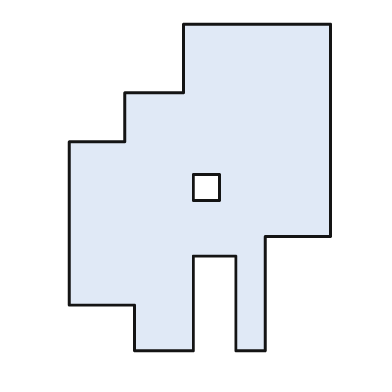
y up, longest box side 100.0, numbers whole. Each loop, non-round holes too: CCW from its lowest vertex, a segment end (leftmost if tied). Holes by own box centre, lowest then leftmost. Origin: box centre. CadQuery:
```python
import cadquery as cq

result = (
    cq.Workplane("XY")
    .moveTo(-20.0, -50.0)
    .lineTo(-2.0, -50.0)
    .lineTo(-2.0, -21.0)
    .lineTo(11.0, -21.0)
    .lineTo(11.0, -50.0)
    .lineTo(20.0, -50.0)
    .lineTo(20.0, -15.0)
    .lineTo(40.0, -15.0)
    .lineTo(40.0, 50.0)
    .lineTo(-5.0, 50.0)
    .lineTo(-5.0, 29.0)
    .lineTo(-23.0, 29.0)
    .lineTo(-23.0, 14.0)
    .lineTo(-40.0, 14.0)
    .lineTo(-40.0, -36.0)
    .lineTo(-20.0, -36.0)
    .close()
    .moveTo(-2.0, -4.0)
    .lineTo(6.0, -4.0)
    .lineTo(6.0, 4.0)
    .lineTo(-2.0, 4.0)
    .close()
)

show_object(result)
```